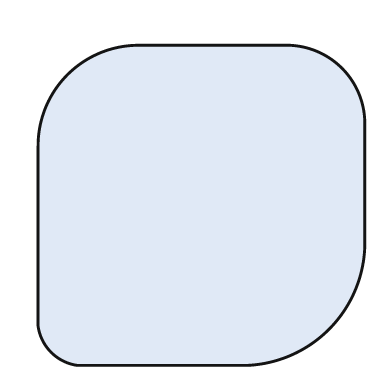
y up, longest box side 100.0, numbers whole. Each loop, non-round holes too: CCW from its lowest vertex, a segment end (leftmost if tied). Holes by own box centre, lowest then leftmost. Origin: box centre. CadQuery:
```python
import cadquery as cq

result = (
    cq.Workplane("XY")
    .moveTo(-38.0, -49.0)
    .lineTo(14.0, -49.0)
    .threePointArc((39.0, -38.0), (50.0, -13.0))
    .lineTo(50.0, 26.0)
    .threePointArc((43.0, 42.0), (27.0, 49.0))
    .lineTo(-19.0, 49.0)
    .threePointArc((-41.0, 40.0), (-50.0, 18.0))
    .lineTo(-50.0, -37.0)
    .threePointArc((-46.0, -45.0), (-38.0, -49.0))
    .close()
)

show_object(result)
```